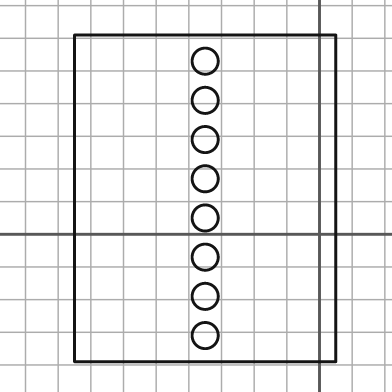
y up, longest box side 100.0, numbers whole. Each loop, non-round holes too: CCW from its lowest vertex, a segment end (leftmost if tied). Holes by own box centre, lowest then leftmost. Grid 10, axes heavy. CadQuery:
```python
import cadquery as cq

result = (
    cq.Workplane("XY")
    .moveTo(-75.0, -39.0)
    .lineTo(5.0, -39.0)
    .lineTo(5.0, 61.0)
    .lineTo(-75.0, 61.0)
    .close()
    .moveTo(-35.0, -31.0)
    .circle(4.0)
    .moveTo(-35.0, -19.0)
    .circle(4.0)
    .moveTo(-35.0, -7.0)
    .circle(4.0)
    .moveTo(-35.0, 5.0)
    .circle(4.0)
    .moveTo(-35.0, 17.0)
    .circle(4.0)
    .moveTo(-35.0, 29.0)
    .circle(4.0)
    .moveTo(-35.0, 41.0)
    .circle(4.0)
    .moveTo(-35.0, 53.0)
    .circle(4.0)
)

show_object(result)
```